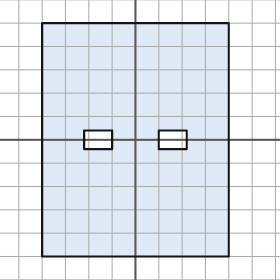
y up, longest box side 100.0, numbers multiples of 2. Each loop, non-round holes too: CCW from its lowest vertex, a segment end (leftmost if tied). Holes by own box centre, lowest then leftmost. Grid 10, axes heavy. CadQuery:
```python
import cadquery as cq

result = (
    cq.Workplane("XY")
    .moveTo(-40.0, -50.0)
    .lineTo(40.0, -50.0)
    .lineTo(40.0, 50.0)
    .lineTo(-40.0, 50.0)
    .close()
    .moveTo(-22.0, -4.0)
    .lineTo(-10.0, -4.0)
    .lineTo(-10.0, 4.0)
    .lineTo(-22.0, 4.0)
    .close()
    .moveTo(10.0, -4.0)
    .lineTo(22.0, -4.0)
    .lineTo(22.0, 4.0)
    .lineTo(10.0, 4.0)
    .close()
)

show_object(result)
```